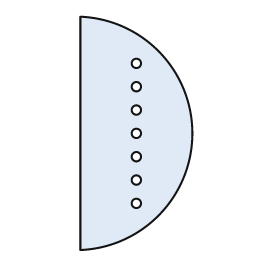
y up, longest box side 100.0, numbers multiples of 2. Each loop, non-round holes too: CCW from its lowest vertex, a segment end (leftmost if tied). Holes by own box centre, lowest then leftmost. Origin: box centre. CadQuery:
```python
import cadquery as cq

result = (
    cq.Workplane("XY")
    .moveTo(-24.0, -50.0)
    .threePointArc((24.0, 0.0), (-24.0, 50.0))
    .close()
    .moveTo(0.0, -30.0)
    .circle(2.0)
    .moveTo(0.0, -20.0)
    .circle(2.0)
    .moveTo(0.0, -10.0)
    .circle(2.0)
    .moveTo(0.0, 0.0)
    .circle(2.0)
    .moveTo(0.0, 10.0)
    .circle(2.0)
    .moveTo(0.0, 20.0)
    .circle(2.0)
    .moveTo(0.0, 30.0)
    .circle(2.0)
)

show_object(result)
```